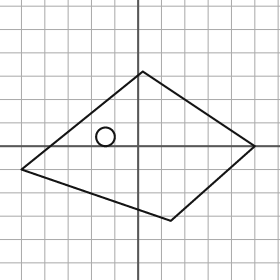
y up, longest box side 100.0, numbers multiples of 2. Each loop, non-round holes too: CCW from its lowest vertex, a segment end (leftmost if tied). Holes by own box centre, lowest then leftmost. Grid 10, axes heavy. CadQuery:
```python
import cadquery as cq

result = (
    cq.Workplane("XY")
    .moveTo(14.0, -32.0)
    .lineTo(50.0, 0.0)
    .lineTo(2.0, 32.0)
    .lineTo(-50.0, -10.0)
    .close()
    .moveTo(-14.0, 4.0)
    .circle(4.0)
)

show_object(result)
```